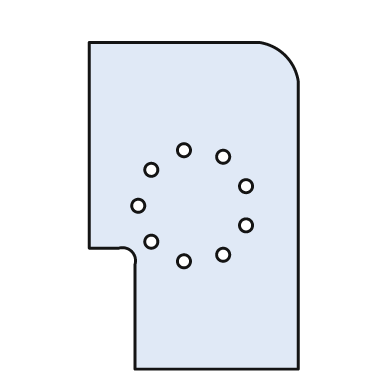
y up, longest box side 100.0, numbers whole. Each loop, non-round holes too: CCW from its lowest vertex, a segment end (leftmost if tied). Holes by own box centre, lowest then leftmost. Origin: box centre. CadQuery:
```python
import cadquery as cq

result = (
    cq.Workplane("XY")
    .moveTo(-18.0, -50.0)
    .lineTo(32.0, -50.0)
    .lineTo(32.0, 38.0)
    .threePointArc((28.0, 46.0), (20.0, 50.0))
    .lineTo(-32.0, 50.0)
    .lineTo(-32.0, -13.0)
    .lineTo(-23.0, -13.0)
    .threePointArc((-19.0, -14.0), (-18.0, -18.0))
    .close()
    .moveTo(-3.0, -17.0)
    .circle(2.0)
    .moveTo(9.0, -15.0)
    .circle(2.0)
    .moveTo(-13.0, -11.0)
    .circle(2.0)
    .moveTo(16.0, -6.0)
    .circle(2.0)
    .moveTo(-17.0, 0.0)
    .circle(2.0)
    .moveTo(16.0, 6.0)
    .circle(2.0)
    .moveTo(-13.0, 11.0)
    .circle(2.0)
    .moveTo(9.0, 15.0)
    .circle(2.0)
    .moveTo(-3.0, 17.0)
    .circle(2.0)
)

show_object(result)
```